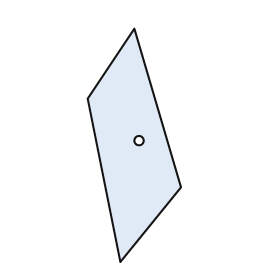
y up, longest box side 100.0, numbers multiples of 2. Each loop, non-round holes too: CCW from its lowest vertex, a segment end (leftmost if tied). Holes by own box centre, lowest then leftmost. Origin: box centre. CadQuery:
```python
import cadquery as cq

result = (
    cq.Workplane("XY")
    .moveTo(-6.0, -50.0)
    .lineTo(20.0, -18.0)
    .lineTo(0.0, 50.0)
    .lineTo(-20.0, 20.0)
    .close()
    .moveTo(2.0, 2.0)
    .circle(2.0)
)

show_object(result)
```